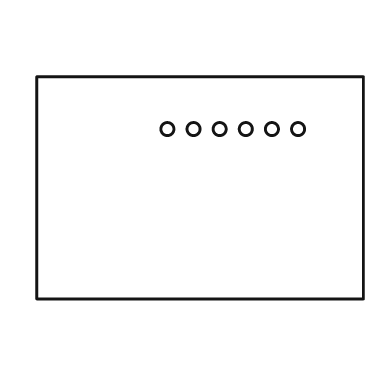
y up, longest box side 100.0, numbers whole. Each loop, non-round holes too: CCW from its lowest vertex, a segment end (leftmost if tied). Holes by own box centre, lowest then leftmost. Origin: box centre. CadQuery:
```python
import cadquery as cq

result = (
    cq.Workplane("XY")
    .moveTo(-50.0, -34.0)
    .lineTo(50.0, -34.0)
    .lineTo(50.0, 34.0)
    .lineTo(-50.0, 34.0)
    .close()
    .moveTo(-10.0, 18.0)
    .circle(2.0)
    .moveTo(-2.0, 18.0)
    .circle(2.0)
    .moveTo(6.0, 18.0)
    .circle(2.0)
    .moveTo(14.0, 18.0)
    .circle(2.0)
    .moveTo(22.0, 18.0)
    .circle(2.0)
    .moveTo(30.0, 18.0)
    .circle(2.0)
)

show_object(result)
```